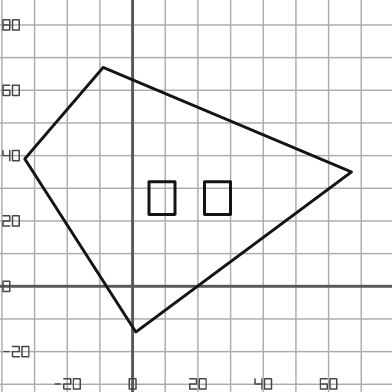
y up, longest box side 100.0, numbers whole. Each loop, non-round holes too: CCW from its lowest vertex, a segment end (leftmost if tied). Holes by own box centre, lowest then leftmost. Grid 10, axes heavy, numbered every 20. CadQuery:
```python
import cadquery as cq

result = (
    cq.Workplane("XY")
    .moveTo(1.0, -14.0)
    .lineTo(67.0, 35.0)
    .lineTo(-9.0, 67.0)
    .lineTo(-33.0, 39.0)
    .close()
    .moveTo(5.0, 22.0)
    .lineTo(13.0, 22.0)
    .lineTo(13.0, 32.0)
    .lineTo(5.0, 32.0)
    .close()
    .moveTo(22.0, 22.0)
    .lineTo(30.0, 22.0)
    .lineTo(30.0, 32.0)
    .lineTo(22.0, 32.0)
    .close()
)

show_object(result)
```